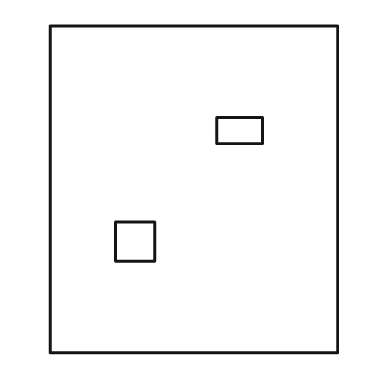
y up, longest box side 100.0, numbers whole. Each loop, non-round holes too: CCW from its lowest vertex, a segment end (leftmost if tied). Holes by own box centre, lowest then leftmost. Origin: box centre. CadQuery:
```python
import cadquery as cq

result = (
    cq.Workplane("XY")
    .moveTo(-44.0, -50.0)
    .lineTo(44.0, -50.0)
    .lineTo(44.0, 50.0)
    .lineTo(-44.0, 50.0)
    .close()
    .moveTo(-24.0, -22.0)
    .lineTo(-12.0, -22.0)
    .lineTo(-12.0, -10.0)
    .lineTo(-24.0, -10.0)
    .close()
    .moveTo(7.0, 14.0)
    .lineTo(21.0, 14.0)
    .lineTo(21.0, 22.0)
    .lineTo(7.0, 22.0)
    .close()
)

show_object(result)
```